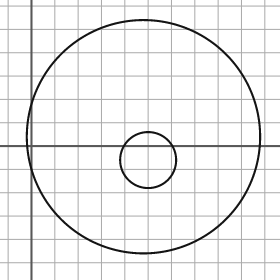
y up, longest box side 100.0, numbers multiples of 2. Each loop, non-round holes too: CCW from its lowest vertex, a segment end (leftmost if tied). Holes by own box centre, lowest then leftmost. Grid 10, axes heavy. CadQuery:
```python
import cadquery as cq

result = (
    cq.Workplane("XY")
    .moveTo(48.0, 4.0)
    .circle(50.0)
    .moveTo(50.0, -6.0)
    .circle(12.0)
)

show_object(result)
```